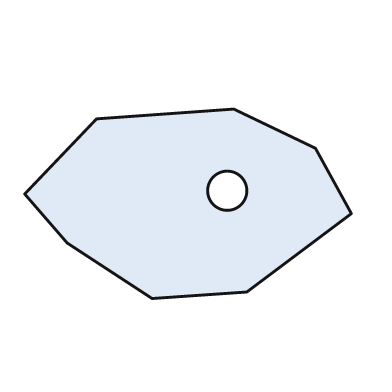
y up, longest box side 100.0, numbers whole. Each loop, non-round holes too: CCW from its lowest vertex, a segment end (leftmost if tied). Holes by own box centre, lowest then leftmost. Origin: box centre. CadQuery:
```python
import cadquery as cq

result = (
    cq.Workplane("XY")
    .moveTo(-11.0, -29.0)
    .lineTo(18.0, -27.0)
    .lineTo(50.0, -3.0)
    .lineTo(39.0, 17.0)
    .lineTo(14.0, 29.0)
    .lineTo(-28.0, 26.0)
    .lineTo(-50.0, 3.0)
    .lineTo(-37.0, -12.0)
    .close()
    .moveTo(12.0, 4.0)
    .circle(6.0)
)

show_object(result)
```